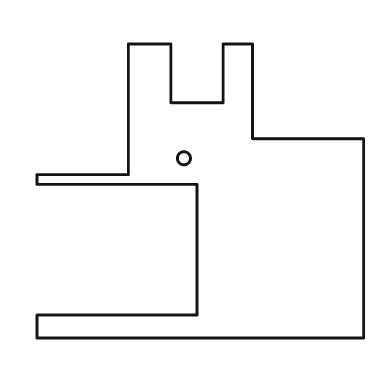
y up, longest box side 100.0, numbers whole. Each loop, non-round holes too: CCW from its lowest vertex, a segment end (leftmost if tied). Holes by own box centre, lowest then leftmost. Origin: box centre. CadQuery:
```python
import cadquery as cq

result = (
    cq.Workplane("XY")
    .moveTo(-50.0, -45.0)
    .lineTo(50.0, -45.0)
    .lineTo(50.0, 16.0)
    .lineTo(16.0, 16.0)
    .lineTo(16.0, 45.0)
    .lineTo(7.0, 45.0)
    .lineTo(7.0, 27.0)
    .lineTo(-9.0, 27.0)
    .lineTo(-9.0, 45.0)
    .lineTo(-22.0, 45.0)
    .lineTo(-22.0, 5.0)
    .lineTo(-50.0, 5.0)
    .lineTo(-50.0, 2.0)
    .lineTo(-1.0, 2.0)
    .lineTo(-1.0, -38.0)
    .lineTo(-50.0, -38.0)
    .close()
    .moveTo(-5.0, 10.0)
    .circle(2.0)
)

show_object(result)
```